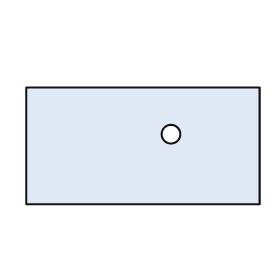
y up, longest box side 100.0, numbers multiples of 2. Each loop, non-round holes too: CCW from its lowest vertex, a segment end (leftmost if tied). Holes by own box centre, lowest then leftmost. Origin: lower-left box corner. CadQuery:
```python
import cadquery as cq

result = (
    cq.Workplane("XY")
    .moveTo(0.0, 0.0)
    .lineTo(100.0, 0.0)
    .lineTo(100.0, 50.0)
    .lineTo(0.0, 50.0)
    .close()
    .moveTo(62.0, 30.0)
    .circle(4.0)
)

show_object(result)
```